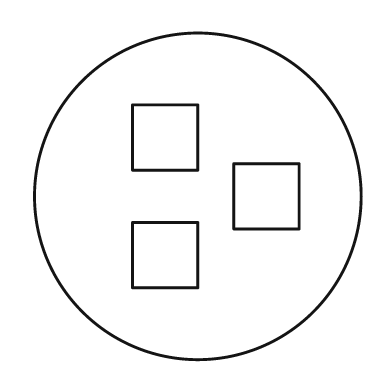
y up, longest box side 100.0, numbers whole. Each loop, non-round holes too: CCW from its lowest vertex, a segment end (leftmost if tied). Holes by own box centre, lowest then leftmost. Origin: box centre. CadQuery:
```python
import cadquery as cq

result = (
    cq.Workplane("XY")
    .moveTo(0.0, 0.0)
    .circle(50.0)
    .moveTo(-20.0, -28.0)
    .lineTo(0.0, -28.0)
    .lineTo(0.0, -8.0)
    .lineTo(-20.0, -8.0)
    .close()
    .moveTo(11.0, -10.0)
    .lineTo(31.0, -10.0)
    .lineTo(31.0, 10.0)
    .lineTo(11.0, 10.0)
    .close()
    .moveTo(-20.0, 8.0)
    .lineTo(0.0, 8.0)
    .lineTo(0.0, 28.0)
    .lineTo(-20.0, 28.0)
    .close()
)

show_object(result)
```